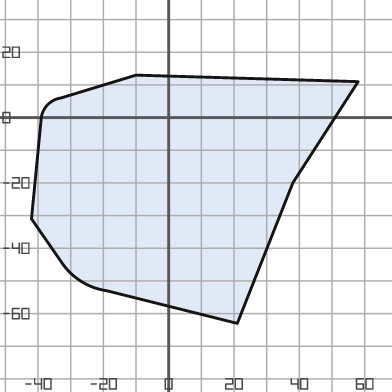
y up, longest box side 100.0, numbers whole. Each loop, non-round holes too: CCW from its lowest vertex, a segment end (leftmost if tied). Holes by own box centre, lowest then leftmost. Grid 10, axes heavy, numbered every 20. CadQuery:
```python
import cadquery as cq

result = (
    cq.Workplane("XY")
    .moveTo(21.0, -63.0)
    .lineTo(38.0, -20.0)
    .lineTo(58.0, 11.0)
    .lineTo(-10.0, 13.0)
    .lineTo(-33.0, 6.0)
    .threePointArc((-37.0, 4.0), (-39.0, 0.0))
    .lineTo(-42.0, -31.0)
    .lineTo(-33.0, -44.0)
    .threePointArc((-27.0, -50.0), (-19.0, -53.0))
    .close()
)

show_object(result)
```